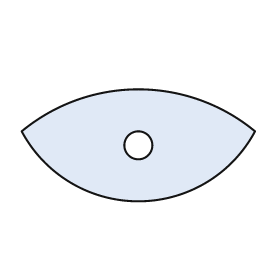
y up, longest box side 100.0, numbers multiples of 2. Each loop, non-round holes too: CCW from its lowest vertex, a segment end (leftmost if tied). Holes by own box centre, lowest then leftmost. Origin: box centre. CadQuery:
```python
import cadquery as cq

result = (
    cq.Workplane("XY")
    .moveTo(-50.0, 6.0)
    .threePointArc((0.0, -24.0), (50.0, 6.0))
    .threePointArc((0.0, 24.0), (-50.0, 6.0))
    .close()
    .moveTo(0.0, 0.0)
    .circle(6.0)
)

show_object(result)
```